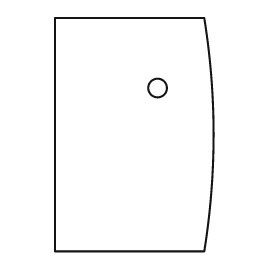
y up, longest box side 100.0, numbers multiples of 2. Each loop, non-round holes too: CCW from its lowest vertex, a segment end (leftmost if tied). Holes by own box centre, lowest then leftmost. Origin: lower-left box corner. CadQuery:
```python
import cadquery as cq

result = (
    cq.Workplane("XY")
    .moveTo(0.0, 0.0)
    .lineTo(64.0, 0.0)
    .threePointArc((68.0, 50.0), (64.0, 100.0))
    .lineTo(0.0, 100.0)
    .close()
    .moveTo(44.0, 70.0)
    .circle(4.0)
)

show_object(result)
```